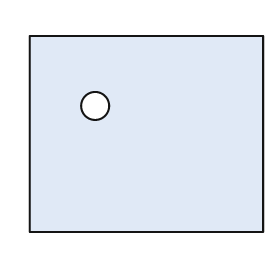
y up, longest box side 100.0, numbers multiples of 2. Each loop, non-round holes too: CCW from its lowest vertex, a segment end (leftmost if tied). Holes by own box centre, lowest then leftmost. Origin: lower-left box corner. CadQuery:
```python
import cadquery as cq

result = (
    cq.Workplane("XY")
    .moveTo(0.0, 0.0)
    .lineTo(100.0, 0.0)
    .lineTo(100.0, 84.0)
    .lineTo(0.0, 84.0)
    .close()
    .moveTo(28.0, 54.0)
    .circle(6.0)
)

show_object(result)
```